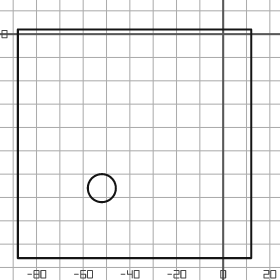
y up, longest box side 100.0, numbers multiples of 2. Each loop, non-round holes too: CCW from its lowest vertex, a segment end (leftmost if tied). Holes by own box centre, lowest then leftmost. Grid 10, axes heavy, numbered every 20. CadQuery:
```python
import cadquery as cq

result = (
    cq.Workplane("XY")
    .moveTo(-88.0, -96.0)
    .lineTo(12.0, -96.0)
    .lineTo(12.0, 2.0)
    .lineTo(-88.0, 2.0)
    .close()
    .moveTo(-52.0, -66.0)
    .circle(6.0)
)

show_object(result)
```